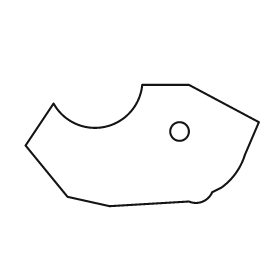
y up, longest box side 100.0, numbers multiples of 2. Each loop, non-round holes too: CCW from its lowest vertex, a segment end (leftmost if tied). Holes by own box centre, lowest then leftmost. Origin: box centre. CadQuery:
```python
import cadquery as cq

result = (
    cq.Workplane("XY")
    .moveTo(-14.0, -26.0)
    .lineTo(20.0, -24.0)
    .threePointArc((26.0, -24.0), (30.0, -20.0))
    .lineTo(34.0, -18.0)
    .threePointArc((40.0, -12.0), (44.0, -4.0))
    .lineTo(50.0, 10.0)
    .lineTo(20.0, 26.0)
    .lineTo(0.0, 26.0)
    .threePointArc((-16.0, 8.0), (-38.0, 18.0))
    .lineTo(-50.0, 0.0)
    .lineTo(-32.0, -22.0)
    .close()
    .moveTo(16.0, 6.0)
    .circle(4.0)
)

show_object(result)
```